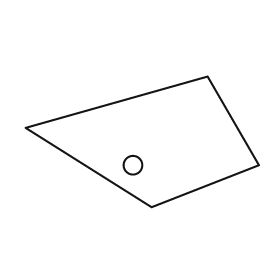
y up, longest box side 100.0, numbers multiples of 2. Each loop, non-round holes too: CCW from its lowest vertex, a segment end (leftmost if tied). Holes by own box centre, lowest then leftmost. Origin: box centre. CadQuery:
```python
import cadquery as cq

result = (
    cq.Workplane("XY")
    .moveTo(4.0, -28.0)
    .lineTo(50.0, -10.0)
    .lineTo(28.0, 28.0)
    .lineTo(-50.0, 6.0)
    .close()
    .moveTo(-4.0, -10.0)
    .circle(4.0)
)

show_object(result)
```